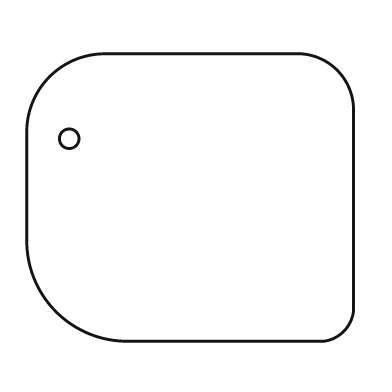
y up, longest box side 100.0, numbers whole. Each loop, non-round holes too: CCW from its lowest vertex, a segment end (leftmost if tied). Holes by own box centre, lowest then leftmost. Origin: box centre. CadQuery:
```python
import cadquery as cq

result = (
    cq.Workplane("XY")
    .moveTo(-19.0, -44.0)
    .lineTo(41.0, -44.0)
    .threePointArc((47.0, -41.0), (50.0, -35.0))
    .lineTo(50.0, 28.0)
    .threePointArc((45.0, 39.0), (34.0, 44.0))
    .lineTo(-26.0, 44.0)
    .threePointArc((-43.0, 37.0), (-50.0, 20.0))
    .lineTo(-50.0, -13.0)
    .threePointArc((-41.0, -35.0), (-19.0, -44.0))
    .close()
    .moveTo(-37.0, 18.0)
    .circle(3.0)
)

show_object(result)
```